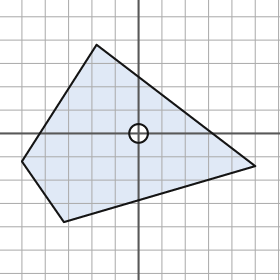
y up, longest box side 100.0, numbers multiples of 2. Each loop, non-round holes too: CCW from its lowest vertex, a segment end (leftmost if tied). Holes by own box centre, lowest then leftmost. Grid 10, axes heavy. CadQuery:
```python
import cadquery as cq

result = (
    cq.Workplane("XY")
    .moveTo(-32.0, -38.0)
    .lineTo(50.0, -14.0)
    .lineTo(-18.0, 38.0)
    .lineTo(-50.0, -12.0)
    .close()
    .moveTo(0.0, 0.0)
    .circle(4.0)
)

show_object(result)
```